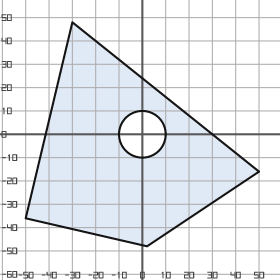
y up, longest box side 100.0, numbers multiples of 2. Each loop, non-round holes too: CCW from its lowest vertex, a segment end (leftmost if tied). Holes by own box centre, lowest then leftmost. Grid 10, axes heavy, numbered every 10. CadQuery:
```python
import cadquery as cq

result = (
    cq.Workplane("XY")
    .moveTo(2.0, -48.0)
    .lineTo(50.0, -16.0)
    .lineTo(-30.0, 48.0)
    .lineTo(-50.0, -36.0)
    .close()
    .moveTo(0.0, 0.0)
    .circle(10.0)
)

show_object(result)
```